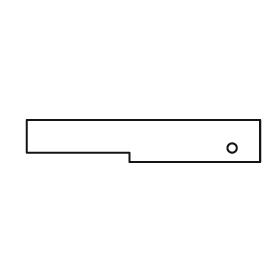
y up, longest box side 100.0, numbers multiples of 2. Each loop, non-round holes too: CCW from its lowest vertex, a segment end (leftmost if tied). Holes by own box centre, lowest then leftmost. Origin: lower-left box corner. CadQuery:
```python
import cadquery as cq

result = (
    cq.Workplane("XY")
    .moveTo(44.0, 0.0)
    .lineTo(100.0, 0.0)
    .lineTo(100.0, 18.0)
    .lineTo(0.0, 18.0)
    .lineTo(0.0, 4.0)
    .lineTo(44.0, 4.0)
    .close()
    .moveTo(88.0, 6.0)
    .circle(2.0)
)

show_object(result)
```